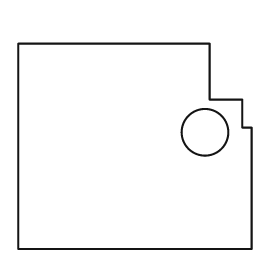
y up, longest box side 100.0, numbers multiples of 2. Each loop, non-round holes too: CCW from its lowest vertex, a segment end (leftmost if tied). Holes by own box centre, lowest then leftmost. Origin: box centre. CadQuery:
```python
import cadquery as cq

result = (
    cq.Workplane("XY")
    .moveTo(-50.0, -44.0)
    .lineTo(50.0, -44.0)
    .lineTo(50.0, 8.0)
    .lineTo(46.0, 8.0)
    .lineTo(46.0, 20.0)
    .lineTo(32.0, 20.0)
    .lineTo(32.0, 44.0)
    .lineTo(-50.0, 44.0)
    .close()
    .moveTo(30.0, 6.0)
    .circle(10.0)
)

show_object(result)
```